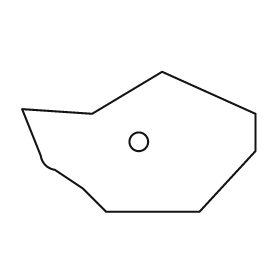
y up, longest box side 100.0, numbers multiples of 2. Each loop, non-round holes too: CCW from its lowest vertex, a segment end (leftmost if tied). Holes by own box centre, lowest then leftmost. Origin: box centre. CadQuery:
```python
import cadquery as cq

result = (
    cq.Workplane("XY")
    .moveTo(-14.0, -30.0)
    .lineTo(26.0, -30.0)
    .lineTo(50.0, -4.0)
    .lineTo(50.0, 12.0)
    .lineTo(10.0, 30.0)
    .lineTo(-20.0, 12.0)
    .lineTo(-50.0, 14.0)
    .lineTo(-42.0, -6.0)
    .threePointArc((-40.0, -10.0), (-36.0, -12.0))
    .lineTo(-24.0, -20.0)
    .close()
    .moveTo(0.0, 0.0)
    .circle(4.0)
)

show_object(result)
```